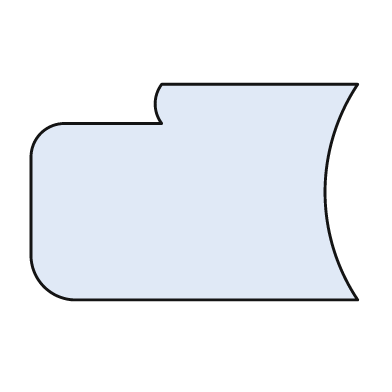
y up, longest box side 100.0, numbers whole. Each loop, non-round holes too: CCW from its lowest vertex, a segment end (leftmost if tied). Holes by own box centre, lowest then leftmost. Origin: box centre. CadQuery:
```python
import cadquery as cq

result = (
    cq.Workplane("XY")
    .moveTo(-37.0, -33.0)
    .lineTo(50.0, -33.0)
    .threePointArc((40.0, 0.0), (50.0, 33.0))
    .lineTo(-10.0, 33.0)
    .threePointArc((-12.0, 27.0), (-10.0, 21.0))
    .lineTo(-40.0, 21.0)
    .threePointArc((-47.0, 18.0), (-50.0, 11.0))
    .lineTo(-50.0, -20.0)
    .threePointArc((-46.0, -29.0), (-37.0, -33.0))
    .close()
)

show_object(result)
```